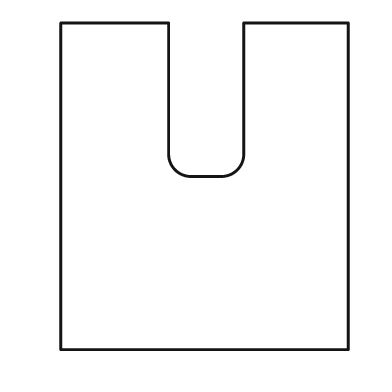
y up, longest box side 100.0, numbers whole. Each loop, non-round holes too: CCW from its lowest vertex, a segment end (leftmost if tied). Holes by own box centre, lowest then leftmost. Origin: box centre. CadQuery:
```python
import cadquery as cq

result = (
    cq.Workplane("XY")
    .moveTo(-44.0, -50.0)
    .lineTo(44.0, -50.0)
    .lineTo(44.0, 50.0)
    .lineTo(12.0, 50.0)
    .lineTo(12.0, 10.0)
    .threePointArc((10.0, 5.0), (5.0, 3.0))
    .lineTo(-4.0, 3.0)
    .threePointArc((-9.0, 5.0), (-11.0, 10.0))
    .lineTo(-11.0, 50.0)
    .lineTo(-44.0, 50.0)
    .close()
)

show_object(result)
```